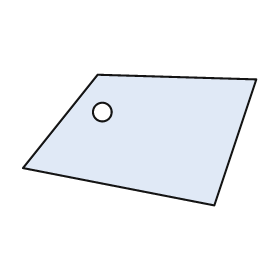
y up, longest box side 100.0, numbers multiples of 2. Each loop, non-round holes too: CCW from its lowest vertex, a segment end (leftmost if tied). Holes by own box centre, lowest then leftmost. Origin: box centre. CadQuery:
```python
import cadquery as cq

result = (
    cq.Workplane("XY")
    .moveTo(32.0, -28.0)
    .lineTo(50.0, 26.0)
    .lineTo(-18.0, 28.0)
    .lineTo(-50.0, -12.0)
    .close()
    .moveTo(-16.0, 12.0)
    .circle(4.0)
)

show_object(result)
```